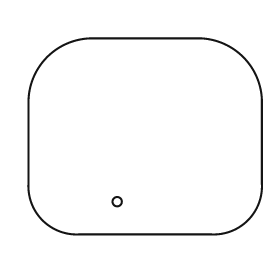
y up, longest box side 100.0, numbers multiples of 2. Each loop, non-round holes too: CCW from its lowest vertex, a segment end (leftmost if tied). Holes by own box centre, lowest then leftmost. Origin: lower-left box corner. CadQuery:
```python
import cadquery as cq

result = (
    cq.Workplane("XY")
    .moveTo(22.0, 0.0)
    .lineTo(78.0, 0.0)
    .threePointArc((94.0, 6.0), (100.0, 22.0))
    .lineTo(100.0, 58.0)
    .threePointArc((92.0, 76.0), (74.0, 84.0))
    .lineTo(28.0, 84.0)
    .threePointArc((8.0, 76.0), (0.0, 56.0))
    .lineTo(0.0, 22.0)
    .threePointArc((6.0, 6.0), (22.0, 0.0))
    .close()
    .moveTo(38.0, 14.0)
    .circle(2.0)
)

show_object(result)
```